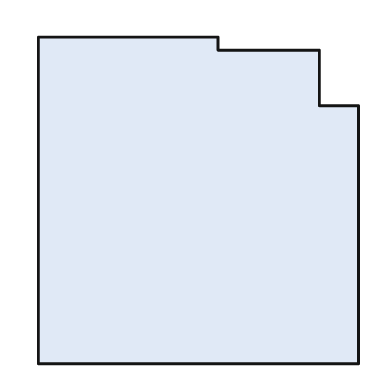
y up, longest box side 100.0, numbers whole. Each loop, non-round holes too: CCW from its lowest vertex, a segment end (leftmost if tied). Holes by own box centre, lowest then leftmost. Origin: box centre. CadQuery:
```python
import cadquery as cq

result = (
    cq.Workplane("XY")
    .moveTo(-49.0, -50.0)
    .lineTo(49.0, -50.0)
    .lineTo(49.0, 29.0)
    .lineTo(37.0, 29.0)
    .lineTo(37.0, 46.0)
    .lineTo(6.0, 46.0)
    .lineTo(6.0, 50.0)
    .lineTo(-49.0, 50.0)
    .close()
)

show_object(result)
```